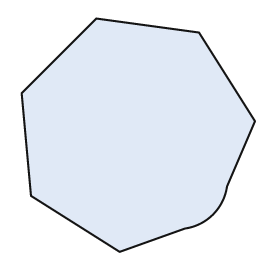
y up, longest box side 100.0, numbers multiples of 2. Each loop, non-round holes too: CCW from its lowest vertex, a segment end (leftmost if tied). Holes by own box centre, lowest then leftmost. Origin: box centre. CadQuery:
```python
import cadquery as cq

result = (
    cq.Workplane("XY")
    .moveTo(-8.0, -50.0)
    .lineTo(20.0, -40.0)
    .threePointArc((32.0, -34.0), (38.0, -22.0))
    .lineTo(50.0, 6.0)
    .lineTo(26.0, 44.0)
    .lineTo(-18.0, 50.0)
    .lineTo(-50.0, 18.0)
    .lineTo(-46.0, -26.0)
    .close()
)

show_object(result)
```